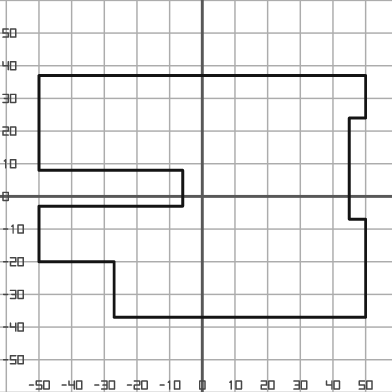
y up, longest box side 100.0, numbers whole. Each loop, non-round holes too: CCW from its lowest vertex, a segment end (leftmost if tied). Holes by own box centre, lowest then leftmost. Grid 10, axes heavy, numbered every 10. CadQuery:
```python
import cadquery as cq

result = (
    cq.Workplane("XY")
    .moveTo(-27.0, -37.0)
    .lineTo(50.0, -37.0)
    .lineTo(50.0, -7.0)
    .lineTo(45.0, -7.0)
    .lineTo(45.0, 24.0)
    .lineTo(50.0, 24.0)
    .lineTo(50.0, 37.0)
    .lineTo(-50.0, 37.0)
    .lineTo(-50.0, 8.0)
    .lineTo(-6.0, 8.0)
    .lineTo(-6.0, -3.0)
    .lineTo(-50.0, -3.0)
    .lineTo(-50.0, -20.0)
    .lineTo(-27.0, -20.0)
    .close()
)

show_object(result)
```